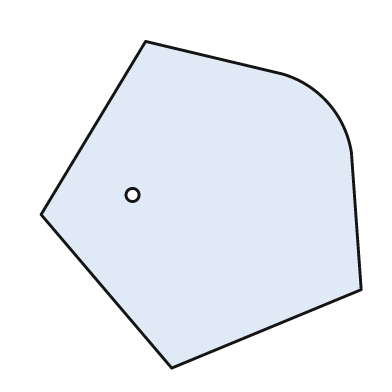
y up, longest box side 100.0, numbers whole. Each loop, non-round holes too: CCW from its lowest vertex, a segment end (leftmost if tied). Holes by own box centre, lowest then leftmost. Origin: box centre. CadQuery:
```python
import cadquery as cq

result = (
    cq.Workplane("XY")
    .moveTo(-9.0, -50.0)
    .lineTo(49.0, -26.0)
    .lineTo(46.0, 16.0)
    .threePointArc((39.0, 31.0), (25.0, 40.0))
    .lineTo(-17.0, 50.0)
    .lineTo(-49.0, -3.0)
    .close()
    .moveTo(-21.0, 3.0)
    .circle(2.0)
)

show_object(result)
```